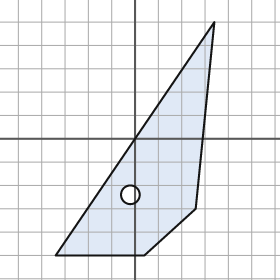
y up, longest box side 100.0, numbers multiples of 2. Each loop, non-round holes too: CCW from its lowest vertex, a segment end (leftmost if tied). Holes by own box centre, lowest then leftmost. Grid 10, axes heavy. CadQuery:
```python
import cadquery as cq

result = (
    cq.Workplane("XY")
    .moveTo(-34.0, -50.0)
    .lineTo(4.0, -50.0)
    .lineTo(26.0, -30.0)
    .lineTo(34.0, 50.0)
    .close()
    .moveTo(-2.0, -24.0)
    .circle(4.0)
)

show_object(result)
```